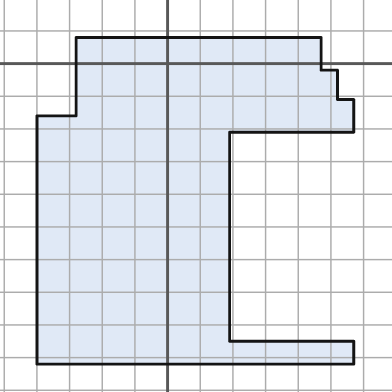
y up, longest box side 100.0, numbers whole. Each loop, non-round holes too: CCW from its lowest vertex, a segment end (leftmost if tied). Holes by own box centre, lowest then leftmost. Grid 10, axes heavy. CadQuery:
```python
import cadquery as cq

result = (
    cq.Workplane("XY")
    .moveTo(-40.0, -92.0)
    .lineTo(57.0, -92.0)
    .lineTo(57.0, -85.0)
    .lineTo(19.0, -85.0)
    .lineTo(19.0, -21.0)
    .lineTo(57.0, -21.0)
    .lineTo(57.0, -11.0)
    .lineTo(52.0, -11.0)
    .lineTo(52.0, -2.0)
    .lineTo(47.0, -2.0)
    .lineTo(47.0, 8.0)
    .lineTo(-28.0, 8.0)
    .lineTo(-28.0, -16.0)
    .lineTo(-40.0, -16.0)
    .close()
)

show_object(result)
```